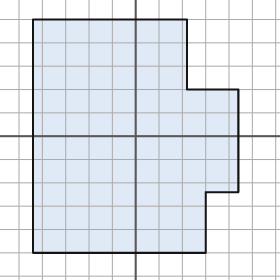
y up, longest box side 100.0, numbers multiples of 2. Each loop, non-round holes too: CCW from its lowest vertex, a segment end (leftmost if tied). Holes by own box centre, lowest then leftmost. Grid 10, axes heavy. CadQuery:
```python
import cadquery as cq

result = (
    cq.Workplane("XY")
    .moveTo(-44.0, -50.0)
    .lineTo(30.0, -50.0)
    .lineTo(30.0, -24.0)
    .lineTo(44.0, -24.0)
    .lineTo(44.0, 20.0)
    .lineTo(22.0, 20.0)
    .lineTo(22.0, 50.0)
    .lineTo(-44.0, 50.0)
    .close()
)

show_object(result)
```